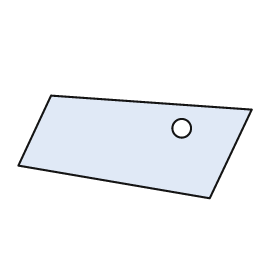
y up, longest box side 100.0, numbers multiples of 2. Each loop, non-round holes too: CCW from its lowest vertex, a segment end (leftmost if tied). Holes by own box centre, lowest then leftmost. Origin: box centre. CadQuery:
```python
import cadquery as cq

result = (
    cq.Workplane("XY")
    .moveTo(32.0, -22.0)
    .lineTo(50.0, 16.0)
    .lineTo(-36.0, 22.0)
    .lineTo(-50.0, -8.0)
    .close()
    .moveTo(20.0, 8.0)
    .circle(4.0)
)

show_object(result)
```